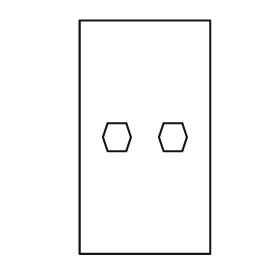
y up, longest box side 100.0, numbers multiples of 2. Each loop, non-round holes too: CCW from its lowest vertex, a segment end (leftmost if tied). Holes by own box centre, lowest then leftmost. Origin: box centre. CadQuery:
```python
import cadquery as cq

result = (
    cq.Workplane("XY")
    .moveTo(-28.0, -50.0)
    .lineTo(28.0, -50.0)
    .lineTo(28.0, 50.0)
    .lineTo(-28.0, 50.0)
    .close()
    .moveTo(-16.0, -6.0)
    .lineTo(-8.0, -6.0)
    .lineTo(-6.0, 0.0)
    .lineTo(-8.0, 6.0)
    .lineTo(-16.0, 6.0)
    .lineTo(-18.0, 0.0)
    .close()
    .moveTo(8.0, -6.0)
    .lineTo(16.0, -6.0)
    .lineTo(18.0, 0.0)
    .lineTo(16.0, 6.0)
    .lineTo(8.0, 6.0)
    .lineTo(6.0, 0.0)
    .close()
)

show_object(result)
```